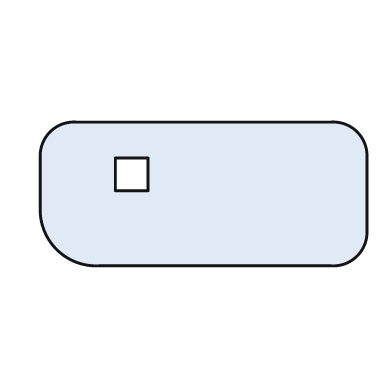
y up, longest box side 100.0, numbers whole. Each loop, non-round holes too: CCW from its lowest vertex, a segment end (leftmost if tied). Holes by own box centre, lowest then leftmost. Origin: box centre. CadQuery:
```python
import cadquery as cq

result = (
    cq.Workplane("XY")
    .moveTo(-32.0, -22.0)
    .lineTo(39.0, -22.0)
    .threePointArc((47.0, -19.0), (50.0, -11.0))
    .lineTo(50.0, 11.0)
    .threePointArc((47.0, 19.0), (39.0, 22.0))
    .lineTo(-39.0, 22.0)
    .threePointArc((-47.0, 19.0), (-50.0, 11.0))
    .lineTo(-50.0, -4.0)
    .threePointArc((-45.0, -17.0), (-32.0, -22.0))
    .close()
    .moveTo(-27.0, 1.0)
    .lineTo(-17.0, 1.0)
    .lineTo(-17.0, 11.0)
    .lineTo(-27.0, 11.0)
    .close()
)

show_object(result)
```